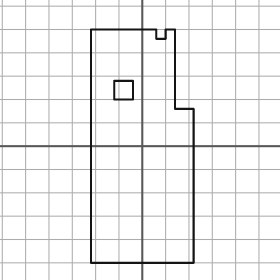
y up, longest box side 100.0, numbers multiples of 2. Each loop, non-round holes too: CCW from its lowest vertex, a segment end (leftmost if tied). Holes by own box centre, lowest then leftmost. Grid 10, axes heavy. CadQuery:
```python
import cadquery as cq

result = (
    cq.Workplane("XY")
    .moveTo(-22.0, -50.0)
    .lineTo(22.0, -50.0)
    .lineTo(22.0, 16.0)
    .lineTo(14.0, 16.0)
    .lineTo(14.0, 50.0)
    .lineTo(10.0, 50.0)
    .lineTo(10.0, 46.0)
    .lineTo(6.0, 46.0)
    .lineTo(6.0, 50.0)
    .lineTo(-22.0, 50.0)
    .close()
    .moveTo(-12.0, 20.0)
    .lineTo(-4.0, 20.0)
    .lineTo(-4.0, 28.0)
    .lineTo(-12.0, 28.0)
    .close()
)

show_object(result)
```